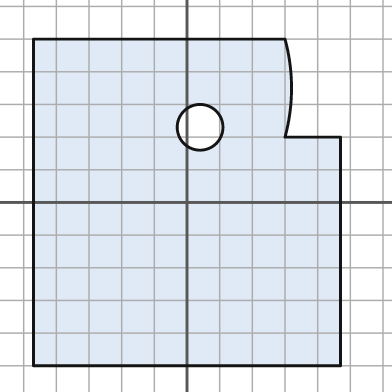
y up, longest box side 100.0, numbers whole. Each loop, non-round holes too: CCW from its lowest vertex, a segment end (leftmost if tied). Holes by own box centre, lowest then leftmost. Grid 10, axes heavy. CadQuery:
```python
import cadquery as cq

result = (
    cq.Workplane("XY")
    .moveTo(-47.0, -50.0)
    .lineTo(47.0, -50.0)
    .lineTo(47.0, 20.0)
    .lineTo(30.0, 20.0)
    .threePointArc((32.0, 35.0), (30.0, 50.0))
    .lineTo(-47.0, 50.0)
    .close()
    .moveTo(4.0, 23.0)
    .circle(7.0)
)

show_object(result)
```